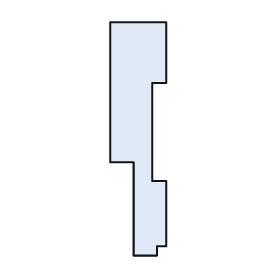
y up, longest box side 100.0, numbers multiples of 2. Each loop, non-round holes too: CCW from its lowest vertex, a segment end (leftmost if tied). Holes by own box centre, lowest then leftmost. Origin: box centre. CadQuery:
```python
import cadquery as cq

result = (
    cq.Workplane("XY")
    .moveTo(-2.0, -50.0)
    .lineTo(8.0, -50.0)
    .lineTo(8.0, -46.0)
    .lineTo(12.0, -46.0)
    .lineTo(12.0, -18.0)
    .lineTo(6.0, -18.0)
    .lineTo(6.0, 24.0)
    .lineTo(12.0, 24.0)
    .lineTo(12.0, 50.0)
    .lineTo(-12.0, 50.0)
    .lineTo(-12.0, -10.0)
    .lineTo(-2.0, -10.0)
    .close()
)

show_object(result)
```